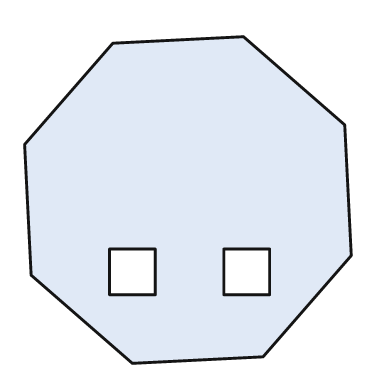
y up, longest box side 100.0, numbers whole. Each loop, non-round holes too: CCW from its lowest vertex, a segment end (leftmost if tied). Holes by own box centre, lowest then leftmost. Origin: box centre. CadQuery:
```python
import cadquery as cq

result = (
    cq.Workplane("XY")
    .moveTo(-17.0, -50.0)
    .lineTo(23.0, -48.0)
    .lineTo(50.0, -17.0)
    .lineTo(48.0, 23.0)
    .lineTo(17.0, 50.0)
    .lineTo(-23.0, 48.0)
    .lineTo(-50.0, 17.0)
    .lineTo(-48.0, -23.0)
    .close()
    .moveTo(-24.0, -29.0)
    .lineTo(-10.0, -29.0)
    .lineTo(-10.0, -15.0)
    .lineTo(-24.0, -15.0)
    .close()
    .moveTo(11.0, -29.0)
    .lineTo(25.0, -29.0)
    .lineTo(25.0, -15.0)
    .lineTo(11.0, -15.0)
    .close()
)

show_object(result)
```